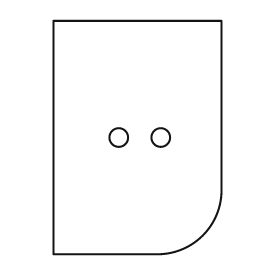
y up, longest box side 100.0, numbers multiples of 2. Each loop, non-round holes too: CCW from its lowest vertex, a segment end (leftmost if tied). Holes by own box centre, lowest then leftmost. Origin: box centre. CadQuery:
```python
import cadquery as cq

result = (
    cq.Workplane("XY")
    .moveTo(-36.0, -50.0)
    .lineTo(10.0, -50.0)
    .threePointArc((28.0, -42.0), (36.0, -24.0))
    .lineTo(36.0, 50.0)
    .lineTo(-36.0, 50.0)
    .close()
    .moveTo(-8.0, 0.0)
    .circle(4.0)
    .moveTo(10.0, 0.0)
    .circle(4.0)
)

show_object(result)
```